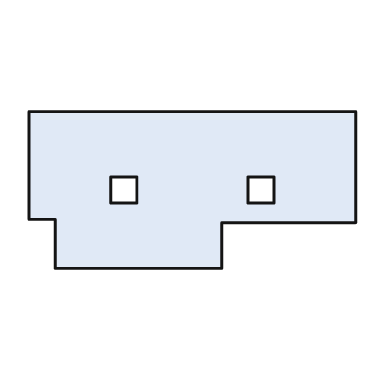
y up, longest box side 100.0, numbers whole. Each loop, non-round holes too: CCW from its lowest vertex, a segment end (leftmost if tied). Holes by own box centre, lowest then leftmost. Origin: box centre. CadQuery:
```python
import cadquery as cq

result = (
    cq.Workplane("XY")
    .moveTo(-42.0, -24.0)
    .lineTo(9.0, -24.0)
    .lineTo(9.0, -10.0)
    .lineTo(50.0, -10.0)
    .lineTo(50.0, 24.0)
    .lineTo(-50.0, 24.0)
    .lineTo(-50.0, -9.0)
    .lineTo(-42.0, -9.0)
    .close()
    .moveTo(-25.0, -4.0)
    .lineTo(-17.0, -4.0)
    .lineTo(-17.0, 4.0)
    .lineTo(-25.0, 4.0)
    .close()
    .moveTo(17.0, -4.0)
    .lineTo(25.0, -4.0)
    .lineTo(25.0, 4.0)
    .lineTo(17.0, 4.0)
    .close()
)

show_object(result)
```